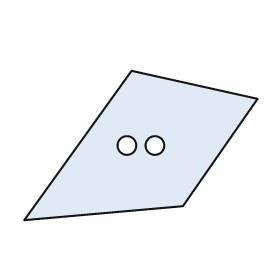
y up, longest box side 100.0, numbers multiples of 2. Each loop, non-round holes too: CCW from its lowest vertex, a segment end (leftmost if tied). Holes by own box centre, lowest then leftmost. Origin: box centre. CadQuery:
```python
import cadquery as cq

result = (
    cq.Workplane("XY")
    .moveTo(-50.0, -32.0)
    .lineTo(18.0, -26.0)
    .lineTo(50.0, 20.0)
    .lineTo(-4.0, 32.0)
    .close()
    .moveTo(-6.0, 0.0)
    .circle(4.0)
    .moveTo(6.0, 0.0)
    .circle(4.0)
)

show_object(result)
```